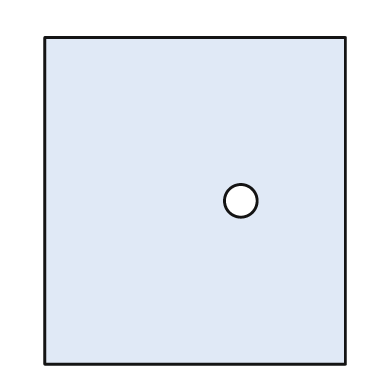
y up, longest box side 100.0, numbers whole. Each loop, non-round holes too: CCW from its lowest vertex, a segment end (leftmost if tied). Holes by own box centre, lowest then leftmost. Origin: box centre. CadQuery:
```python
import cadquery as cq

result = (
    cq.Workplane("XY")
    .moveTo(-46.0, -50.0)
    .lineTo(46.0, -50.0)
    .lineTo(46.0, 50.0)
    .lineTo(-46.0, 50.0)
    .close()
    .moveTo(14.0, 0.0)
    .circle(5.0)
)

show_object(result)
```